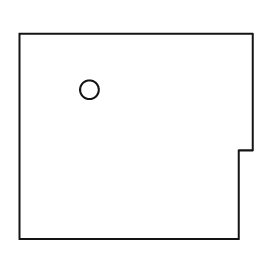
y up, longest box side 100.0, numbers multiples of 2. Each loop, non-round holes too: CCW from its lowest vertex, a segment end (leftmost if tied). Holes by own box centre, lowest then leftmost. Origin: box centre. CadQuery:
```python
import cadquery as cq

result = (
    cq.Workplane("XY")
    .moveTo(-50.0, -44.0)
    .lineTo(44.0, -44.0)
    .lineTo(44.0, -6.0)
    .lineTo(50.0, -6.0)
    .lineTo(50.0, 44.0)
    .lineTo(-50.0, 44.0)
    .close()
    .moveTo(-20.0, 20.0)
    .circle(4.0)
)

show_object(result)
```